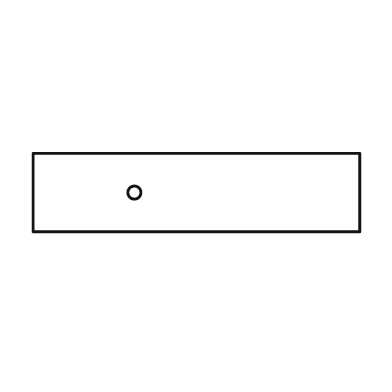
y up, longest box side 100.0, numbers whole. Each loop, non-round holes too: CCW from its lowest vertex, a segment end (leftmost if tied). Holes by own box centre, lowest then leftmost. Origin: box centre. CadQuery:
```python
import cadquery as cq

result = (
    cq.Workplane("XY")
    .moveTo(-50.0, -12.0)
    .lineTo(50.0, -12.0)
    .lineTo(50.0, 12.0)
    .lineTo(-50.0, 12.0)
    .close()
    .moveTo(-19.0, 0.0)
    .circle(2.0)
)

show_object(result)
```